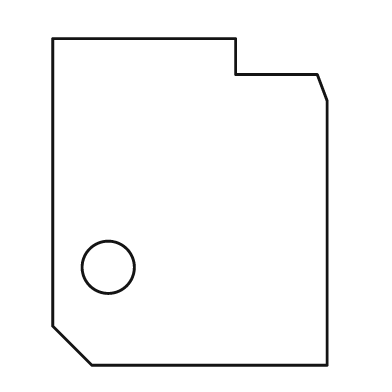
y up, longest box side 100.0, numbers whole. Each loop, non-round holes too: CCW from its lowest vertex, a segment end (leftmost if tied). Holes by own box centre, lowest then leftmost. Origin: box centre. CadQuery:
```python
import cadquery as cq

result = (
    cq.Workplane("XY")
    .moveTo(-30.0, -50.0)
    .lineTo(42.0, -50.0)
    .lineTo(42.0, 31.0)
    .lineTo(39.0, 39.0)
    .lineTo(14.0, 39.0)
    .lineTo(14.0, 50.0)
    .lineTo(-42.0, 50.0)
    .lineTo(-42.0, -38.0)
    .close()
    .moveTo(-25.0, -20.0)
    .circle(8.0)
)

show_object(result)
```